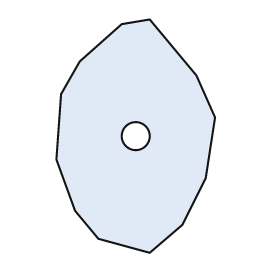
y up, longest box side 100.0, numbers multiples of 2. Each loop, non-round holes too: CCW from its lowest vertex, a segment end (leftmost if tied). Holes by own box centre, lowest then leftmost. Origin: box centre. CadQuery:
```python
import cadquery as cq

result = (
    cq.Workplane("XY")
    .moveTo(6.0, -50.0)
    .lineTo(20.0, -38.0)
    .lineTo(30.0, -18.0)
    .lineTo(34.0, 8.0)
    .lineTo(26.0, 26.0)
    .lineTo(6.0, 50.0)
    .lineTo(-6.0, 48.0)
    .lineTo(-24.0, 32.0)
    .lineTo(-32.0, 18.0)
    .lineTo(-34.0, -10.0)
    .lineTo(-26.0, -32.0)
    .lineTo(-16.0, -44.0)
    .close()
    .moveTo(0.0, 0.0)
    .circle(6.0)
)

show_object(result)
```